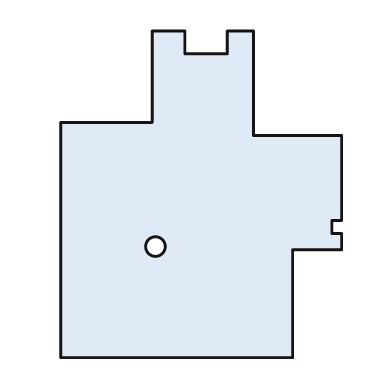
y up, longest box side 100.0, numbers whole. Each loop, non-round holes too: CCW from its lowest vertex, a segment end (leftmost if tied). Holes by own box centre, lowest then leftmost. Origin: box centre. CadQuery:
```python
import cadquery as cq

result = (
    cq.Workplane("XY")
    .moveTo(-43.0, -50.0)
    .lineTo(28.0, -50.0)
    .lineTo(28.0, -17.0)
    .lineTo(43.0, -17.0)
    .lineTo(43.0, -12.0)
    .lineTo(40.0, -12.0)
    .lineTo(40.0, -8.0)
    .lineTo(43.0, -8.0)
    .lineTo(43.0, 18.0)
    .lineTo(16.0, 18.0)
    .lineTo(16.0, 50.0)
    .lineTo(8.0, 50.0)
    .lineTo(8.0, 43.0)
    .lineTo(-5.0, 43.0)
    .lineTo(-5.0, 50.0)
    .lineTo(-15.0, 50.0)
    .lineTo(-15.0, 22.0)
    .lineTo(-43.0, 22.0)
    .close()
    .moveTo(-14.0, -16.0)
    .circle(3.0)
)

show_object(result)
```